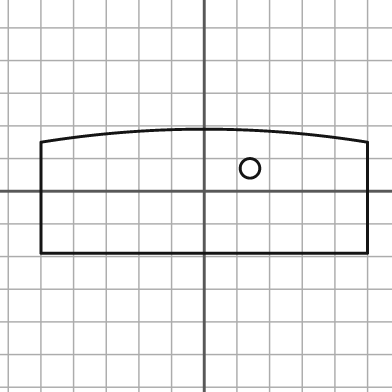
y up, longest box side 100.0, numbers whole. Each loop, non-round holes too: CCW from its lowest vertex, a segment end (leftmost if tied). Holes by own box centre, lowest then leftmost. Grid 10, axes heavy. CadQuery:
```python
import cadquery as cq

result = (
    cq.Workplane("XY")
    .moveTo(-50.0, -19.0)
    .lineTo(50.0, -19.0)
    .lineTo(50.0, 15.0)
    .threePointArc((0.0, 19.0), (-50.0, 15.0))
    .close()
    .moveTo(14.0, 7.0)
    .circle(3.0)
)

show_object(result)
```